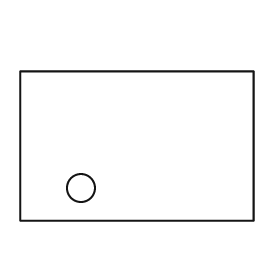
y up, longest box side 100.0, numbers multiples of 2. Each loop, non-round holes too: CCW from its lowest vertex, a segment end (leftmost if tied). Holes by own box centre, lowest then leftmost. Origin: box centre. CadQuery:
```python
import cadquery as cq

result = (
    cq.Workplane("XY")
    .moveTo(-50.0, -32.0)
    .lineTo(50.0, -32.0)
    .lineTo(50.0, 32.0)
    .lineTo(-50.0, 32.0)
    .close()
    .moveTo(-24.0, -18.0)
    .circle(6.0)
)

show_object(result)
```